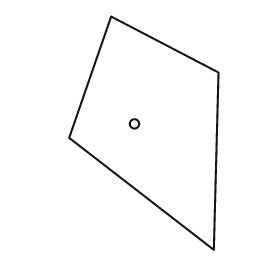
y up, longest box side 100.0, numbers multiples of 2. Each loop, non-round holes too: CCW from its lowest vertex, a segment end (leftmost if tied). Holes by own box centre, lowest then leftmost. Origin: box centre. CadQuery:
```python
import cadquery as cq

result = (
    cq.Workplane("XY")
    .moveTo(30.0, -50.0)
    .lineTo(32.0, 26.0)
    .lineTo(-14.0, 50.0)
    .lineTo(-32.0, -2.0)
    .close()
    .moveTo(-4.0, 4.0)
    .circle(2.0)
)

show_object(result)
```